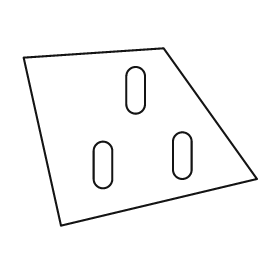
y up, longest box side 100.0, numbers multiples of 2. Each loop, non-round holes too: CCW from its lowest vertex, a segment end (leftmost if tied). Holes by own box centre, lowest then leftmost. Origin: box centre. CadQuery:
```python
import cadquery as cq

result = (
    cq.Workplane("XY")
    .moveTo(-34.0, -38.0)
    .lineTo(50.0, -18.0)
    .lineTo(10.0, 38.0)
    .lineTo(-50.0, 34.0)
    .close()
    .moveTo(-20.0, -18.0)
    .threePointArc((-16.0, -22.0), (-12.0, -18.0))
    .lineTo(-12.0, -6.0)
    .threePointArc((-16.0, -2.0), (-20.0, -6.0))
    .close()
    .moveTo(14.0, -14.0)
    .threePointArc((18.0, -18.0), (22.0, -14.0))
    .lineTo(22.0, -2.0)
    .threePointArc((18.0, 2.0), (14.0, -2.0))
    .close()
    .moveTo(-6.0, 14.0)
    .threePointArc((-2.0, 10.0), (2.0, 14.0))
    .lineTo(2.0, 26.0)
    .threePointArc((-2.0, 30.0), (-6.0, 26.0))
    .close()
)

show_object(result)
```